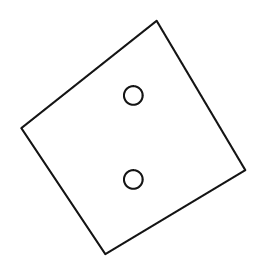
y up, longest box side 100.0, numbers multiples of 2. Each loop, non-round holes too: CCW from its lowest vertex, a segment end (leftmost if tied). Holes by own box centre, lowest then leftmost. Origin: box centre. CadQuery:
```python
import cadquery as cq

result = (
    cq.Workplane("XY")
    .moveTo(-12.0, -50.0)
    .lineTo(48.0, -14.0)
    .lineTo(10.0, 50.0)
    .lineTo(-48.0, 4.0)
    .close()
    .moveTo(0.0, -18.0)
    .circle(4.0)
    .moveTo(0.0, 18.0)
    .circle(4.0)
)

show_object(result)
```